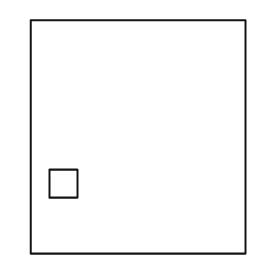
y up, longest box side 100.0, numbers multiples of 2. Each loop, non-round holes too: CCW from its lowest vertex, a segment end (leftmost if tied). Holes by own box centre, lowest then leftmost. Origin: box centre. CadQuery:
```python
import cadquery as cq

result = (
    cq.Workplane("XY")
    .moveTo(-46.0, -50.0)
    .lineTo(46.0, -50.0)
    .lineTo(46.0, 50.0)
    .lineTo(-46.0, 50.0)
    .close()
    .moveTo(-38.0, -26.0)
    .lineTo(-26.0, -26.0)
    .lineTo(-26.0, -14.0)
    .lineTo(-38.0, -14.0)
    .close()
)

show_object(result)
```